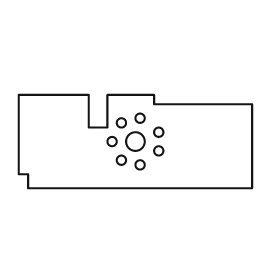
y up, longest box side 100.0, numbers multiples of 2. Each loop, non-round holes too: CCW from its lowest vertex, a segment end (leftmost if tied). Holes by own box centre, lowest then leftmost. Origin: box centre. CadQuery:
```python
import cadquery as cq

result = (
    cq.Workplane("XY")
    .moveTo(-46.0, -20.0)
    .lineTo(50.0, -20.0)
    .lineTo(50.0, 16.0)
    .lineTo(8.0, 16.0)
    .lineTo(8.0, 20.0)
    .lineTo(-12.0, 20.0)
    .lineTo(-12.0, 6.0)
    .lineTo(-20.0, 6.0)
    .lineTo(-20.0, 20.0)
    .lineTo(-50.0, 20.0)
    .lineTo(-50.0, -14.0)
    .lineTo(-46.0, -14.0)
    .close()
    .moveTo(2.0, -10.0)
    .circle(2.0)
    .moveTo(-6.0, -8.0)
    .circle(2.0)
    .moveTo(10.0, -4.0)
    .circle(2.0)
    .moveTo(-10.0, 0.0)
    .circle(2.0)
    .moveTo(0.0, 0.0)
    .circle(4.0)
    .moveTo(10.0, 4.0)
    .circle(2.0)
    .moveTo(-6.0, 8.0)
    .circle(2.0)
    .moveTo(2.0, 10.0)
    .circle(2.0)
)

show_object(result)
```